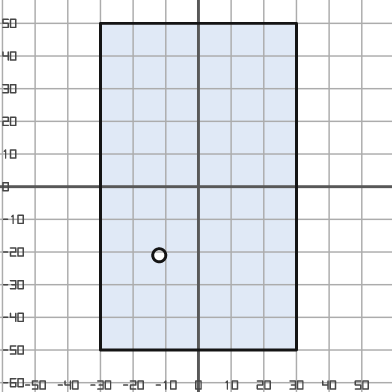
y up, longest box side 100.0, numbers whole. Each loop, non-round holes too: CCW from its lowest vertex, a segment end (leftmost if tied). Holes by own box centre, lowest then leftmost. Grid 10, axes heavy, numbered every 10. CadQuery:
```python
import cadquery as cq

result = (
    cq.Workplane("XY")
    .moveTo(-30.0, -50.0)
    .lineTo(30.0, -50.0)
    .lineTo(30.0, 50.0)
    .lineTo(-30.0, 50.0)
    .close()
    .moveTo(-12.0, -21.0)
    .circle(2.0)
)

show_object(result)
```